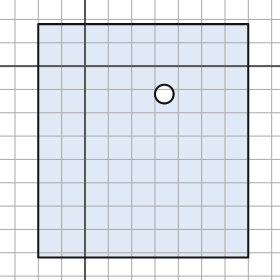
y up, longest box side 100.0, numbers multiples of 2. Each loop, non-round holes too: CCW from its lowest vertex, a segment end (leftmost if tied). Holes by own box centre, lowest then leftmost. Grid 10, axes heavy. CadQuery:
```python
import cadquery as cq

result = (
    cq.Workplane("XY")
    .moveTo(-20.0, -82.0)
    .lineTo(70.0, -82.0)
    .lineTo(70.0, 18.0)
    .lineTo(-20.0, 18.0)
    .close()
    .moveTo(34.0, -12.0)
    .circle(4.0)
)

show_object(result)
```